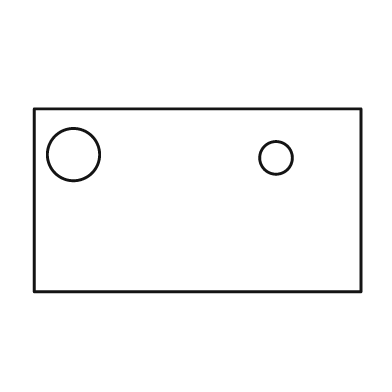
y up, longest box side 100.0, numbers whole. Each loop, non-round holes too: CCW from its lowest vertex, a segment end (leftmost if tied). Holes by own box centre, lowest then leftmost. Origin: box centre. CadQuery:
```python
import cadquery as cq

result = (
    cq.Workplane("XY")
    .moveTo(-50.0, -28.0)
    .lineTo(50.0, -28.0)
    .lineTo(50.0, 28.0)
    .lineTo(-50.0, 28.0)
    .close()
    .moveTo(24.0, 13.0)
    .circle(5.0)
    .moveTo(-38.0, 14.0)
    .circle(8.0)
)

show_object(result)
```